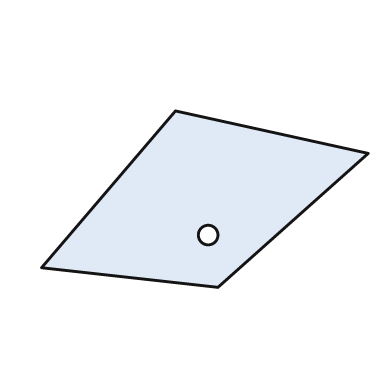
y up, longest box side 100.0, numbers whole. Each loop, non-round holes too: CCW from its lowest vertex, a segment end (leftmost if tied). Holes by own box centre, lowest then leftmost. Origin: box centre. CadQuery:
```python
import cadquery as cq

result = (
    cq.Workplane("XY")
    .moveTo(4.0, -27.0)
    .lineTo(50.0, 14.0)
    .lineTo(-9.0, 27.0)
    .lineTo(-50.0, -21.0)
    .close()
    .moveTo(1.0, -11.0)
    .circle(3.0)
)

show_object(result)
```